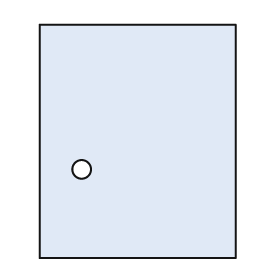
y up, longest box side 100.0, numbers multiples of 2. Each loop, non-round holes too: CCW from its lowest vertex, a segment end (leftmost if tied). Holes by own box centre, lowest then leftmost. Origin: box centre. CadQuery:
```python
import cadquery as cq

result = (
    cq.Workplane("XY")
    .moveTo(-42.0, -50.0)
    .lineTo(42.0, -50.0)
    .lineTo(42.0, 50.0)
    .lineTo(-42.0, 50.0)
    .close()
    .moveTo(-24.0, -12.0)
    .circle(4.0)
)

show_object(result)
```